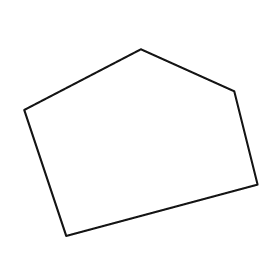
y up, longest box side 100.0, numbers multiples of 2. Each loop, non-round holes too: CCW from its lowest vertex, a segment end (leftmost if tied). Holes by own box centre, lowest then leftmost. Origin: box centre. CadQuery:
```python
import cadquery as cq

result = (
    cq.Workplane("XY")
    .moveTo(-32.0, -40.0)
    .lineTo(50.0, -18.0)
    .lineTo(40.0, 22.0)
    .lineTo(0.0, 40.0)
    .lineTo(-50.0, 14.0)
    .close()
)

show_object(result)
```